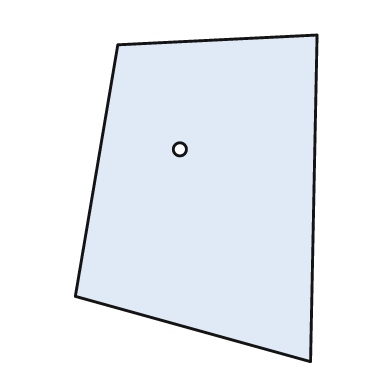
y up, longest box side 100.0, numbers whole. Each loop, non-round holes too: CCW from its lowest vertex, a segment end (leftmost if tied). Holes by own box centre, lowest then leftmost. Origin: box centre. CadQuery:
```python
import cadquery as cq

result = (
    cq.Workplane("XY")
    .moveTo(35.0, -50.0)
    .lineTo(37.0, 50.0)
    .lineTo(-24.0, 47.0)
    .lineTo(-37.0, -30.0)
    .close()
    .moveTo(-5.0, 15.0)
    .circle(2.0)
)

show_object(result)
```